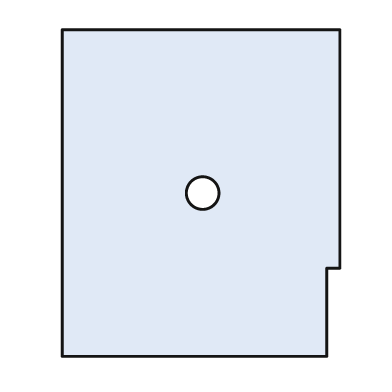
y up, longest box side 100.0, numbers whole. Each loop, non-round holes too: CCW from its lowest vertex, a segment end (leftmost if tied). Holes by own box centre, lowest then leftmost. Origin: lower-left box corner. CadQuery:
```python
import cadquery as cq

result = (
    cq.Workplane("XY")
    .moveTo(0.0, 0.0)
    .lineTo(81.0, 0.0)
    .lineTo(81.0, 27.0)
    .lineTo(85.0, 27.0)
    .lineTo(85.0, 100.0)
    .lineTo(0.0, 100.0)
    .close()
    .moveTo(43.0, 50.0)
    .circle(5.0)
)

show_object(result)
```